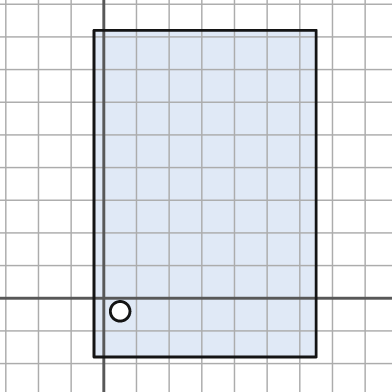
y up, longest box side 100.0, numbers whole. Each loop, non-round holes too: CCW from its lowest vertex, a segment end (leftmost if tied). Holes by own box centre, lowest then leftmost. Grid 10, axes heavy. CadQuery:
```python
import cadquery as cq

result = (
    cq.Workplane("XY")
    .moveTo(-3.0, -18.0)
    .lineTo(65.0, -18.0)
    .lineTo(65.0, 82.0)
    .lineTo(-3.0, 82.0)
    .close()
    .moveTo(5.0, -4.0)
    .circle(3.0)
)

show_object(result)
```